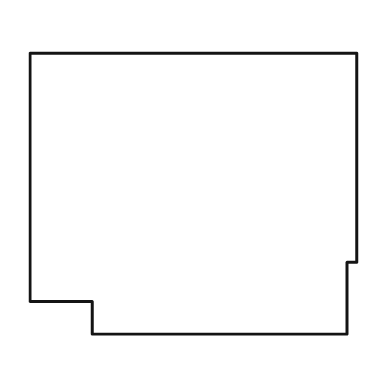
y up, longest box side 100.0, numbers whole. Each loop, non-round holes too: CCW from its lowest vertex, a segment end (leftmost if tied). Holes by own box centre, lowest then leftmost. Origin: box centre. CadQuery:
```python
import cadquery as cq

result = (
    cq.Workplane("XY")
    .moveTo(-31.0, -43.0)
    .lineTo(47.0, -43.0)
    .lineTo(47.0, -21.0)
    .lineTo(50.0, -21.0)
    .lineTo(50.0, 43.0)
    .lineTo(-50.0, 43.0)
    .lineTo(-50.0, -33.0)
    .lineTo(-31.0, -33.0)
    .close()
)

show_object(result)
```